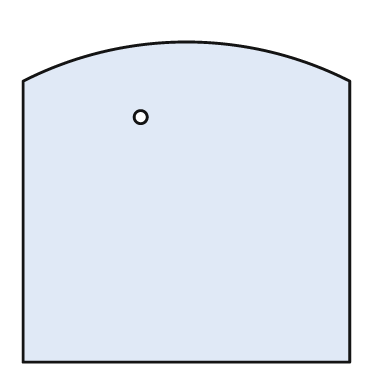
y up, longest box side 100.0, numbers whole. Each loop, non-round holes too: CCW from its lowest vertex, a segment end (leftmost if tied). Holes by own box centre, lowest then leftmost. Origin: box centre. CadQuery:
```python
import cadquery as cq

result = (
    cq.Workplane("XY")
    .moveTo(-50.0, -49.0)
    .lineTo(50.0, -49.0)
    .lineTo(50.0, 37.0)
    .threePointArc((0.0, 49.0), (-50.0, 37.0))
    .close()
    .moveTo(-14.0, 26.0)
    .circle(2.0)
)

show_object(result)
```